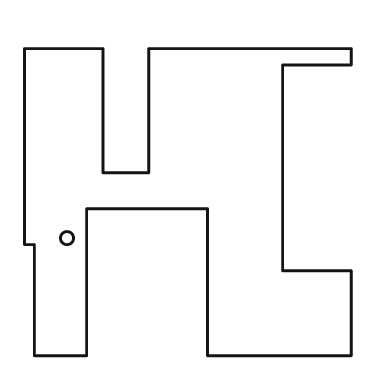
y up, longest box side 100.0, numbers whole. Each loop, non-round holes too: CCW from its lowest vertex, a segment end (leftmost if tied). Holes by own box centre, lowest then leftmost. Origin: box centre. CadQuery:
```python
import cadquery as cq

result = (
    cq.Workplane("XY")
    .moveTo(-47.0, -47.0)
    .lineTo(-31.0, -47.0)
    .lineTo(-31.0, -2.0)
    .lineTo(6.0, -2.0)
    .lineTo(6.0, -47.0)
    .lineTo(50.0, -47.0)
    .lineTo(50.0, -21.0)
    .lineTo(29.0, -21.0)
    .lineTo(29.0, 42.0)
    .lineTo(50.0, 42.0)
    .lineTo(50.0, 47.0)
    .lineTo(-12.0, 47.0)
    .lineTo(-12.0, 9.0)
    .lineTo(-26.0, 9.0)
    .lineTo(-26.0, 47.0)
    .lineTo(-50.0, 47.0)
    .lineTo(-50.0, -13.0)
    .lineTo(-47.0, -13.0)
    .close()
    .moveTo(-37.0, -11.0)
    .circle(2.0)
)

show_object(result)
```